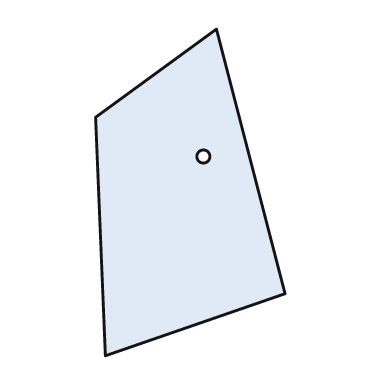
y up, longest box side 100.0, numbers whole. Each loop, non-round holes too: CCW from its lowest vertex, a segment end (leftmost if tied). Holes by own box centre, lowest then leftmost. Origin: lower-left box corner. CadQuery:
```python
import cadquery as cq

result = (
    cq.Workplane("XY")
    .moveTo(3.0, 0.0)
    .lineTo(58.0, 19.0)
    .lineTo(37.0, 100.0)
    .lineTo(0.0, 73.0)
    .close()
    .moveTo(33.0, 61.0)
    .circle(2.0)
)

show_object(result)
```